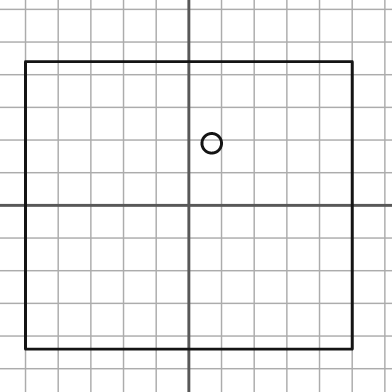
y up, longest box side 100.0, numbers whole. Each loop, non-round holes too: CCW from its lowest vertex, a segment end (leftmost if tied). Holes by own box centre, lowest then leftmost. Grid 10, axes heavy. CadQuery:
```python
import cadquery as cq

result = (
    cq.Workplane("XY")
    .moveTo(-50.0, -44.0)
    .lineTo(50.0, -44.0)
    .lineTo(50.0, 44.0)
    .lineTo(-50.0, 44.0)
    .close()
    .moveTo(7.0, 19.0)
    .circle(3.0)
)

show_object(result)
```